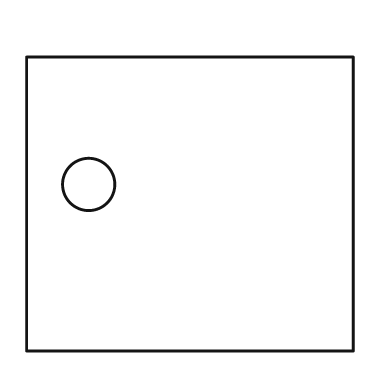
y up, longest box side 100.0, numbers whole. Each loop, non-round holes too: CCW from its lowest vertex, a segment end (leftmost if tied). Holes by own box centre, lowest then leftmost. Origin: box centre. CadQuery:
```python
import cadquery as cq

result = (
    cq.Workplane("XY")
    .moveTo(-50.0, -45.0)
    .lineTo(50.0, -45.0)
    .lineTo(50.0, 45.0)
    .lineTo(-50.0, 45.0)
    .close()
    .moveTo(-31.0, 6.0)
    .circle(8.0)
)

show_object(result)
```